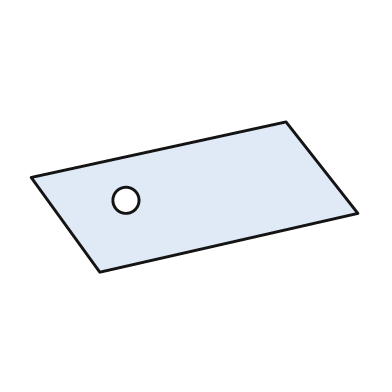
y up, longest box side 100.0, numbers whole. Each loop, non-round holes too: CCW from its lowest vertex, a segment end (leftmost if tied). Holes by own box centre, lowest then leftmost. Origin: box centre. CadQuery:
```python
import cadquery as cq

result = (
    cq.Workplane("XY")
    .moveTo(-29.0, -23.0)
    .lineTo(50.0, -5.0)
    .lineTo(28.0, 23.0)
    .lineTo(-50.0, 6.0)
    .close()
    .moveTo(-21.0, -1.0)
    .circle(4.0)
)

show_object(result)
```